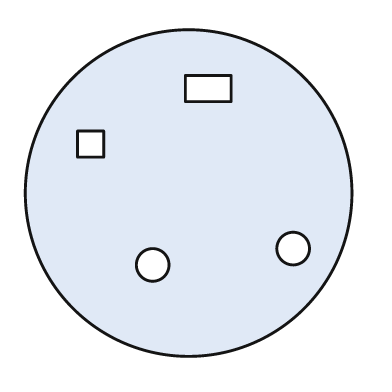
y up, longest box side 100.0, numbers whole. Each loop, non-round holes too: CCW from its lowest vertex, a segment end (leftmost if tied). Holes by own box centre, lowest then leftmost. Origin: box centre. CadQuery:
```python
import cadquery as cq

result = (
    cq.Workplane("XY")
    .moveTo(0.0, 0.0)
    .circle(50.0)
    .moveTo(-11.0, -22.0)
    .circle(5.0)
    .moveTo(32.0, -17.0)
    .circle(5.0)
    .moveTo(-34.0, 11.0)
    .lineTo(-26.0, 11.0)
    .lineTo(-26.0, 19.0)
    .lineTo(-34.0, 19.0)
    .close()
    .moveTo(-1.0, 28.0)
    .lineTo(13.0, 28.0)
    .lineTo(13.0, 36.0)
    .lineTo(-1.0, 36.0)
    .close()
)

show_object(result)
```